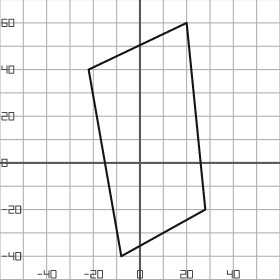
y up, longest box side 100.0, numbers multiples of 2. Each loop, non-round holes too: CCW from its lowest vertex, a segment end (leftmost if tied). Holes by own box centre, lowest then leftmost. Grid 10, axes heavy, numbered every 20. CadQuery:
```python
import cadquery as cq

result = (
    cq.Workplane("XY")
    .moveTo(-8.0, -40.0)
    .lineTo(28.0, -20.0)
    .lineTo(20.0, 60.0)
    .lineTo(-22.0, 40.0)
    .close()
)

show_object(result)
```